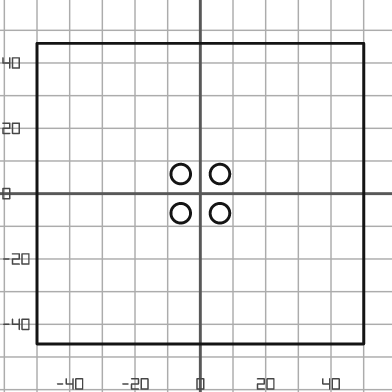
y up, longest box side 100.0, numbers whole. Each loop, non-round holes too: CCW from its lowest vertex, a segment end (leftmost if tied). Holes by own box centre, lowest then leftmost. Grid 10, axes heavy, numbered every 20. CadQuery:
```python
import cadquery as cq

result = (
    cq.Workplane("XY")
    .moveTo(-50.0, -46.0)
    .lineTo(50.0, -46.0)
    .lineTo(50.0, 46.0)
    .lineTo(-50.0, 46.0)
    .close()
    .moveTo(-6.0, -6.0)
    .circle(3.0)
    .moveTo(6.0, -6.0)
    .circle(3.0)
    .moveTo(-6.0, 6.0)
    .circle(3.0)
    .moveTo(6.0, 6.0)
    .circle(3.0)
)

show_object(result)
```